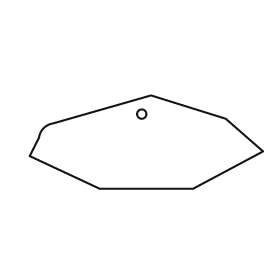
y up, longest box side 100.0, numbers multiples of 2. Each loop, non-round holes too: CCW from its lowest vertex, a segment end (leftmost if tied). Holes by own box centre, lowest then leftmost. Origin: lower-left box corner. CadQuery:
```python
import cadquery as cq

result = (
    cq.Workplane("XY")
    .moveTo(30.0, 0.0)
    .lineTo(70.0, 0.0)
    .lineTo(100.0, 16.0)
    .lineTo(84.0, 30.0)
    .lineTo(52.0, 40.0)
    .lineTo(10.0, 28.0)
    .threePointArc((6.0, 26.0), (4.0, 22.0))
    .lineTo(0.0, 14.0)
    .close()
    .moveTo(48.0, 32.0)
    .circle(2.0)
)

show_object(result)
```